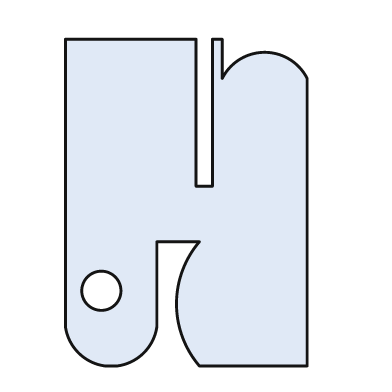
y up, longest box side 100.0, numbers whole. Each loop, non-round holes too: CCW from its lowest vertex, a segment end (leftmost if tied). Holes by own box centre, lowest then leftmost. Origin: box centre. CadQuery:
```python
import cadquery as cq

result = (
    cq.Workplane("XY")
    .moveTo(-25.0, -50.0)
    .lineTo(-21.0, -50.0)
    .threePointArc((-13.0, -46.0), (-9.0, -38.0))
    .lineTo(-9.0, -12.0)
    .lineTo(4.0, -12.0)
    .threePointArc((-3.0, -31.0), (4.0, -50.0))
    .lineTo(37.0, -50.0)
    .lineTo(37.0, 38.0)
    .threePointArc((24.0, 46.0), (11.0, 38.0))
    .lineTo(11.0, 50.0)
    .lineTo(8.0, 50.0)
    .lineTo(8.0, 5.0)
    .lineTo(3.0, 5.0)
    .lineTo(3.0, 50.0)
    .lineTo(-37.0, 50.0)
    .lineTo(-37.0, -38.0)
    .threePointArc((-33.0, -46.0), (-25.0, -50.0))
    .close()
    .moveTo(-26.0, -27.0)
    .circle(6.0)
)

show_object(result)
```